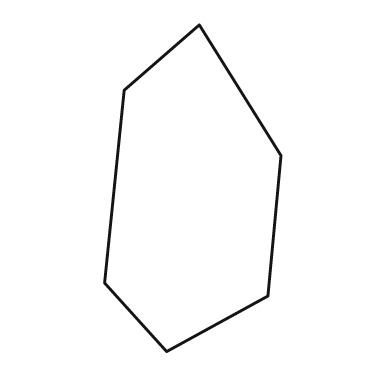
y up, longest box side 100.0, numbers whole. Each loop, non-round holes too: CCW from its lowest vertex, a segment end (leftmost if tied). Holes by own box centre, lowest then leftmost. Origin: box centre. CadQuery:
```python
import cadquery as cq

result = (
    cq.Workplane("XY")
    .moveTo(-8.0, -50.0)
    .lineTo(23.0, -33.0)
    .lineTo(27.0, 10.0)
    .lineTo(2.0, 50.0)
    .lineTo(-21.0, 30.0)
    .lineTo(-27.0, -29.0)
    .close()
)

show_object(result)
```